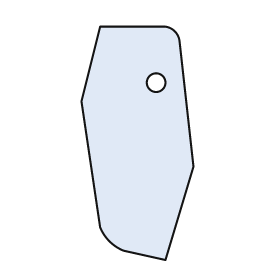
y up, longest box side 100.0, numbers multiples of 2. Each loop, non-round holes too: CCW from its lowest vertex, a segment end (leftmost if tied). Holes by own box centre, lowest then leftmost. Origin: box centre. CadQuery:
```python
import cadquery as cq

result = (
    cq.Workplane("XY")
    .moveTo(12.0, -50.0)
    .lineTo(24.0, -10.0)
    .lineTo(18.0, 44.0)
    .threePointArc((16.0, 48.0), (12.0, 50.0))
    .lineTo(-16.0, 50.0)
    .lineTo(-24.0, 18.0)
    .lineTo(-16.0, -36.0)
    .threePointArc((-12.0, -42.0), (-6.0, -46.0))
    .close()
    .moveTo(8.0, 26.0)
    .circle(4.0)
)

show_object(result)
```